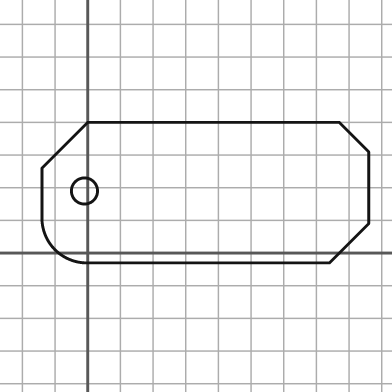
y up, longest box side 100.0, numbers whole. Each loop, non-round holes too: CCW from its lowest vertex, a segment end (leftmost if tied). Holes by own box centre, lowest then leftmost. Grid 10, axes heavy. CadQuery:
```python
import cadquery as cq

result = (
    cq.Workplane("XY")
    .moveTo(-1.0, -3.0)
    .lineTo(74.0, -3.0)
    .lineTo(86.0, 9.0)
    .lineTo(86.0, 31.0)
    .lineTo(77.0, 40.0)
    .lineTo(0.0, 40.0)
    .lineTo(-14.0, 26.0)
    .lineTo(-14.0, 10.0)
    .threePointArc((-10.0, 1.0), (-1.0, -3.0))
    .close()
    .moveTo(-1.0, 19.0)
    .circle(4.0)
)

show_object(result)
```